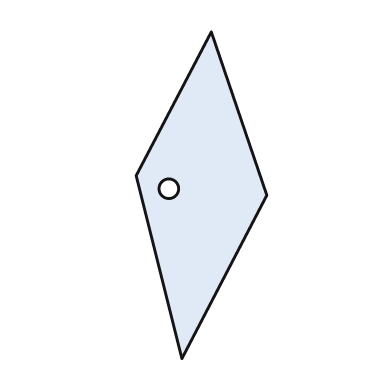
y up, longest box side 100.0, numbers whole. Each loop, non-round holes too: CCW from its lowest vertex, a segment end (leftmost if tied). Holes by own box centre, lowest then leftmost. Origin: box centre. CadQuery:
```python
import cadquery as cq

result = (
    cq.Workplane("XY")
    .moveTo(-6.0, -50.0)
    .lineTo(20.0, 0.0)
    .lineTo(3.0, 50.0)
    .lineTo(-20.0, 6.0)
    .close()
    .moveTo(-10.0, 2.0)
    .circle(3.0)
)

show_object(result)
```